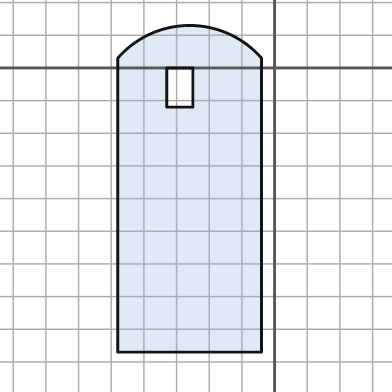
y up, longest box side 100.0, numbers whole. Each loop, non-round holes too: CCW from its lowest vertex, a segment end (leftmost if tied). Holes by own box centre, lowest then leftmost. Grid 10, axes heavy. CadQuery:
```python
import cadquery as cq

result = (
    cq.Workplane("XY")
    .moveTo(-48.0, -87.0)
    .lineTo(-4.0, -87.0)
    .lineTo(-4.0, 3.0)
    .threePointArc((-26.0, 13.0), (-48.0, 3.0))
    .close()
    .moveTo(-33.0, -12.0)
    .lineTo(-25.0, -12.0)
    .lineTo(-25.0, 0.0)
    .lineTo(-33.0, 0.0)
    .close()
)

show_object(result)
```